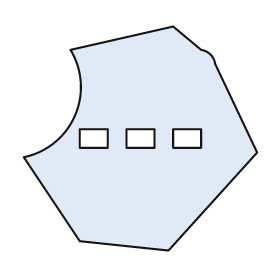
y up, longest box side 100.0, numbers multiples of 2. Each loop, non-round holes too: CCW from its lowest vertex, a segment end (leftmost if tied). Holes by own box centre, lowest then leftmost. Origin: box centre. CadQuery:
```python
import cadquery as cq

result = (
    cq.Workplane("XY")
    .moveTo(12.0, -48.0)
    .lineTo(50.0, -6.0)
    .lineTo(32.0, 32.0)
    .threePointArc((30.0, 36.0), (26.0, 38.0))
    .lineTo(14.0, 48.0)
    .lineTo(-30.0, 38.0)
    .threePointArc((-28.0, 10.0), (-50.0, -8.0))
    .lineTo(-26.0, -44.0)
    .close()
    .moveTo(-26.0, -4.0)
    .lineTo(-14.0, -4.0)
    .lineTo(-14.0, 4.0)
    .lineTo(-26.0, 4.0)
    .close()
    .moveTo(-6.0, -4.0)
    .lineTo(6.0, -4.0)
    .lineTo(6.0, 4.0)
    .lineTo(-6.0, 4.0)
    .close()
    .moveTo(14.0, -4.0)
    .lineTo(26.0, -4.0)
    .lineTo(26.0, 4.0)
    .lineTo(14.0, 4.0)
    .close()
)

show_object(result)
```